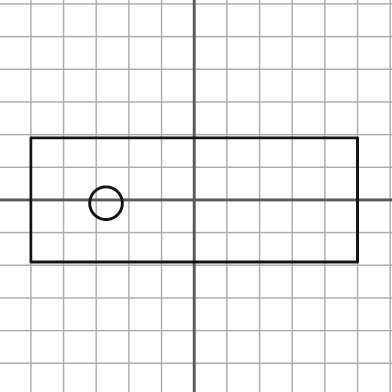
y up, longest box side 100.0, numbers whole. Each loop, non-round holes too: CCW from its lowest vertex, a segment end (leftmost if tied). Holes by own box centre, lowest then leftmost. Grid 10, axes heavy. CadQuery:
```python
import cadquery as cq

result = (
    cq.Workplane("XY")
    .moveTo(-50.0, -19.0)
    .lineTo(50.0, -19.0)
    .lineTo(50.0, 19.0)
    .lineTo(-50.0, 19.0)
    .close()
    .moveTo(-27.0, -1.0)
    .circle(5.0)
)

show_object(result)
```